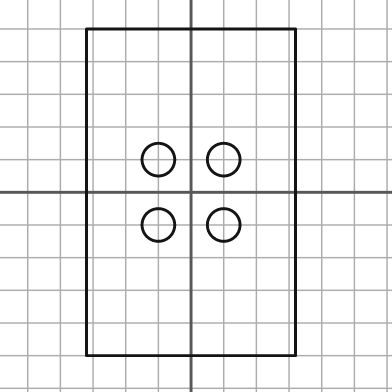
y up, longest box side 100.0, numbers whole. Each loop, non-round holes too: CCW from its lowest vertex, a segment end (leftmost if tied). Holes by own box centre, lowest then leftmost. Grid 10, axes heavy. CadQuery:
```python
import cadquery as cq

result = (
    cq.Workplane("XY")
    .moveTo(-32.0, -50.0)
    .lineTo(32.0, -50.0)
    .lineTo(32.0, 50.0)
    .lineTo(-32.0, 50.0)
    .close()
    .moveTo(-10.0, -10.0)
    .circle(5.0)
    .moveTo(10.0, -10.0)
    .circle(5.0)
    .moveTo(-10.0, 10.0)
    .circle(5.0)
    .moveTo(10.0, 10.0)
    .circle(5.0)
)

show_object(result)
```